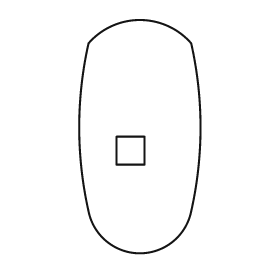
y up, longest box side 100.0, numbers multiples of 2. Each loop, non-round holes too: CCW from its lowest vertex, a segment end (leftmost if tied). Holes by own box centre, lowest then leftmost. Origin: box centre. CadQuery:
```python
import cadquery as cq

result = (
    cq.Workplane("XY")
    .moveTo(-22.0, -32.0)
    .threePointArc((0.0, -50.0), (22.0, -32.0))
    .threePointArc((26.0, 4.0), (22.0, 40.0))
    .threePointArc((0.0, 50.0), (-22.0, 40.0))
    .threePointArc((-26.0, 4.0), (-22.0, -32.0))
    .close()
    .moveTo(-10.0, -12.0)
    .lineTo(2.0, -12.0)
    .lineTo(2.0, 0.0)
    .lineTo(-10.0, 0.0)
    .close()
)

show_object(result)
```